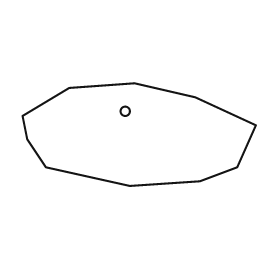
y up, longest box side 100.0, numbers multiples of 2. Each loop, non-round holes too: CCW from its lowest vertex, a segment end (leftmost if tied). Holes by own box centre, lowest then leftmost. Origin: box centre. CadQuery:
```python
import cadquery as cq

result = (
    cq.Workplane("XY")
    .moveTo(-4.0, -22.0)
    .lineTo(26.0, -20.0)
    .lineTo(42.0, -14.0)
    .lineTo(50.0, 4.0)
    .lineTo(24.0, 16.0)
    .lineTo(-2.0, 22.0)
    .lineTo(-30.0, 20.0)
    .lineTo(-50.0, 8.0)
    .lineTo(-48.0, -2.0)
    .lineTo(-40.0, -14.0)
    .close()
    .moveTo(-6.0, 10.0)
    .circle(2.0)
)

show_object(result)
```